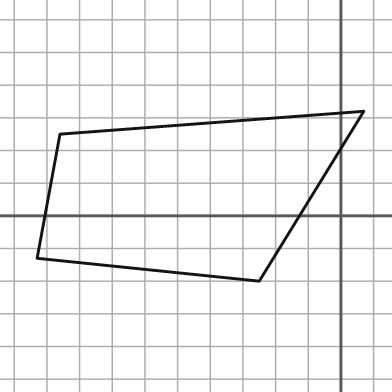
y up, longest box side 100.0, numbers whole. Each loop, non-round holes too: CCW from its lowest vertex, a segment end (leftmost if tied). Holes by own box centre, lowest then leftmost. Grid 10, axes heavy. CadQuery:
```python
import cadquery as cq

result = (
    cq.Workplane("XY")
    .moveTo(-25.0, -20.0)
    .lineTo(7.0, 32.0)
    .lineTo(-86.0, 25.0)
    .lineTo(-93.0, -13.0)
    .close()
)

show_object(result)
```